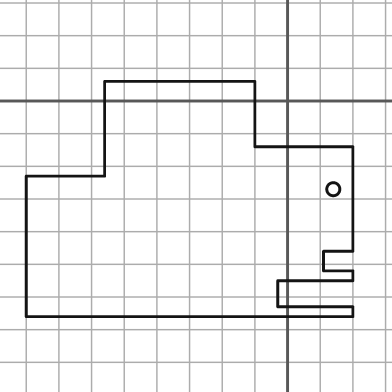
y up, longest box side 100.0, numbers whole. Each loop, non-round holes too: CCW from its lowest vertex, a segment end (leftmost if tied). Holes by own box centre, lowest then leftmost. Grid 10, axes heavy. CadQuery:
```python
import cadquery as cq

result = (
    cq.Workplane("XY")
    .moveTo(-80.0, -66.0)
    .lineTo(20.0, -66.0)
    .lineTo(20.0, -63.0)
    .lineTo(-3.0, -63.0)
    .lineTo(-3.0, -55.0)
    .lineTo(20.0, -55.0)
    .lineTo(20.0, -52.0)
    .lineTo(11.0, -52.0)
    .lineTo(11.0, -46.0)
    .lineTo(20.0, -46.0)
    .lineTo(20.0, -14.0)
    .lineTo(-10.0, -14.0)
    .lineTo(-10.0, 6.0)
    .lineTo(-56.0, 6.0)
    .lineTo(-56.0, -23.0)
    .lineTo(-80.0, -23.0)
    .close()
    .moveTo(14.0, -27.0)
    .circle(2.0)
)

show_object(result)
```